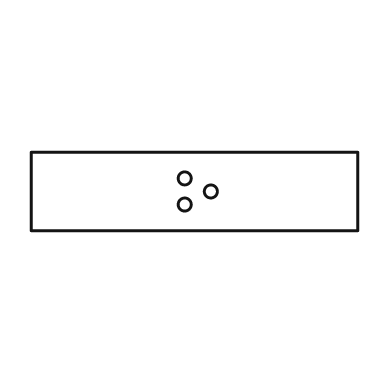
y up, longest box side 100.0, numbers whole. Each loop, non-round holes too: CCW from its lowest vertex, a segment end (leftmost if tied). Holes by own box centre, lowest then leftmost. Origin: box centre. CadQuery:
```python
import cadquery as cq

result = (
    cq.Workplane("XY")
    .moveTo(-50.0, -12.0)
    .lineTo(50.0, -12.0)
    .lineTo(50.0, 12.0)
    .lineTo(-50.0, 12.0)
    .close()
    .moveTo(-3.0, -4.0)
    .circle(2.0)
    .moveTo(5.0, 0.0)
    .circle(2.0)
    .moveTo(-3.0, 4.0)
    .circle(2.0)
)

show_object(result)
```